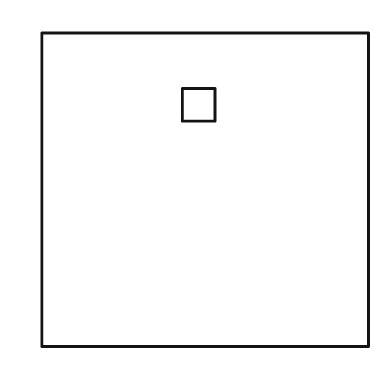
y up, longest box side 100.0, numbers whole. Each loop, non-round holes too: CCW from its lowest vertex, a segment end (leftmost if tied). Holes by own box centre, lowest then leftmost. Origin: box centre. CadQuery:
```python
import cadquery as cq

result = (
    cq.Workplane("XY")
    .moveTo(-50.0, -48.0)
    .lineTo(50.0, -48.0)
    .lineTo(50.0, 48.0)
    .lineTo(-50.0, 48.0)
    .close()
    .moveTo(-7.0, 21.0)
    .lineTo(3.0, 21.0)
    .lineTo(3.0, 31.0)
    .lineTo(-7.0, 31.0)
    .close()
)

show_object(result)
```